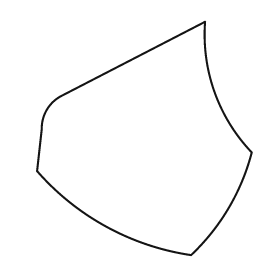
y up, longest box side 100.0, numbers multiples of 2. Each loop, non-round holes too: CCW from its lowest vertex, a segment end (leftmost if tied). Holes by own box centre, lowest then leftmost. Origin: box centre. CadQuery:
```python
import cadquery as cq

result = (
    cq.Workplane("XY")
    .moveTo(20.0, -50.0)
    .threePointArc((36.0, -30.0), (46.0, -6.0))
    .threePointArc((30.0, 20.0), (26.0, 50.0))
    .lineTo(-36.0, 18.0)
    .threePointArc((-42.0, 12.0), (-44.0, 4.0))
    .lineTo(-46.0, -14.0)
    .threePointArc((-16.0, -38.0), (20.0, -50.0))
    .close()
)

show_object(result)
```